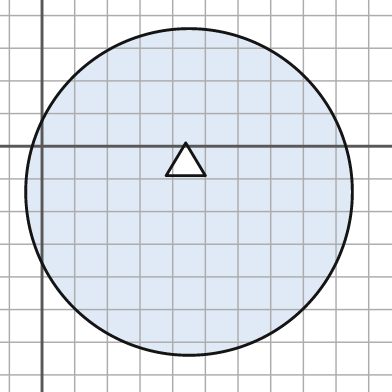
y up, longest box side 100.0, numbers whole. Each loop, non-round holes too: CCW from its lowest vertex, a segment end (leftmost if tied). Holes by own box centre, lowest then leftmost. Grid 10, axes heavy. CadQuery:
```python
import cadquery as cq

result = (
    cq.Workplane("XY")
    .moveTo(45.0, -14.0)
    .circle(50.0)
    .moveTo(38.0, -9.0)
    .lineTo(50.0, -9.0)
    .lineTo(44.0, 1.0)
    .close()
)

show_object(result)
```